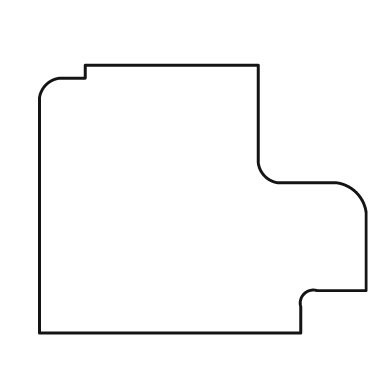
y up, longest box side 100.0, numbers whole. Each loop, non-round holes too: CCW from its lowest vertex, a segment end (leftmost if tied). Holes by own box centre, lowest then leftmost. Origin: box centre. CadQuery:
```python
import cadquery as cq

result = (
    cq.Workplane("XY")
    .moveTo(-50.0, -41.0)
    .lineTo(30.0, -41.0)
    .lineTo(30.0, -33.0)
    .threePointArc((31.0, -29.0), (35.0, -28.0))
    .lineTo(50.0, -28.0)
    .lineTo(50.0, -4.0)
    .threePointArc((47.0, 2.0), (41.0, 5.0))
    .lineTo(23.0, 5.0)
    .threePointArc((19.0, 7.0), (17.0, 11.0))
    .lineTo(17.0, 41.0)
    .lineTo(-36.0, 41.0)
    .lineTo(-36.0, 37.0)
    .lineTo(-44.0, 37.0)
    .threePointArc((-48.0, 35.0), (-50.0, 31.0))
    .close()
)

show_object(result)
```